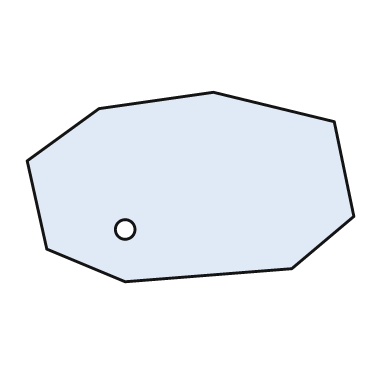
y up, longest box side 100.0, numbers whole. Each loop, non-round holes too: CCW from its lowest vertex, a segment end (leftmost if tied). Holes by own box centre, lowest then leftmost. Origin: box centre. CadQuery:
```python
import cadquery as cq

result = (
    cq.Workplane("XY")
    .moveTo(-20.0, -29.0)
    .lineTo(31.0, -25.0)
    .lineTo(50.0, -9.0)
    .lineTo(44.0, 20.0)
    .lineTo(7.0, 29.0)
    .lineTo(-28.0, 24.0)
    .lineTo(-50.0, 8.0)
    .lineTo(-44.0, -19.0)
    .close()
    .moveTo(-20.0, -13.0)
    .circle(3.0)
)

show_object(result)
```